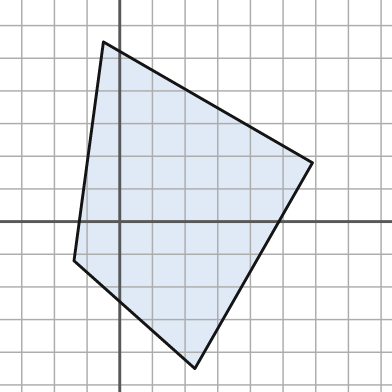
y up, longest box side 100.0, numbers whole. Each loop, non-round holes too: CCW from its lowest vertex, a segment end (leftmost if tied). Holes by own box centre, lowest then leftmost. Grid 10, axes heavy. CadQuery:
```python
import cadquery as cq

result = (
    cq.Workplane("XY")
    .moveTo(23.0, -45.0)
    .lineTo(59.0, 18.0)
    .lineTo(-5.0, 55.0)
    .lineTo(-14.0, -12.0)
    .close()
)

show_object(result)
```